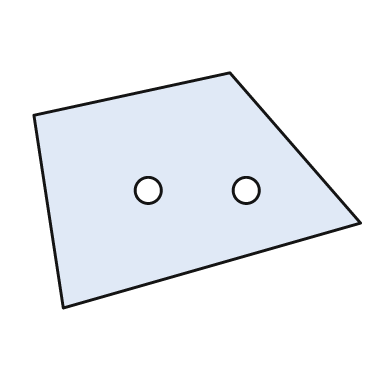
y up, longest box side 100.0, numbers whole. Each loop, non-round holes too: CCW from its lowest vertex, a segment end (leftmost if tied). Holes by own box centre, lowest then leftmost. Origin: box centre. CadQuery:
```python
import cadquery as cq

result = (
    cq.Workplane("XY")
    .moveTo(-41.0, -36.0)
    .lineTo(50.0, -10.0)
    .lineTo(10.0, 36.0)
    .lineTo(-50.0, 23.0)
    .close()
    .moveTo(-15.0, 0.0)
    .circle(4.0)
    .moveTo(15.0, 0.0)
    .circle(4.0)
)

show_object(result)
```